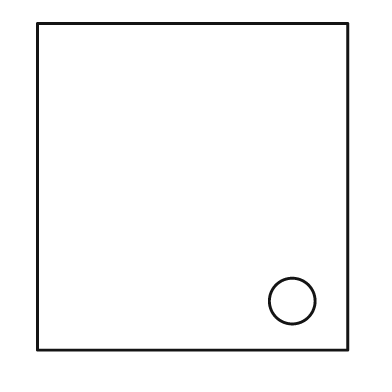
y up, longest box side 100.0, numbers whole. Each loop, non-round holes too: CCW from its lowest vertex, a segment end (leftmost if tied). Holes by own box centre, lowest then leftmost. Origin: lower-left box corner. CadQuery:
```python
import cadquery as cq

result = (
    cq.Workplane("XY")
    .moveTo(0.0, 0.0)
    .lineTo(95.0, 0.0)
    .lineTo(95.0, 100.0)
    .lineTo(0.0, 100.0)
    .close()
    .moveTo(78.0, 15.0)
    .circle(7.0)
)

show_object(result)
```